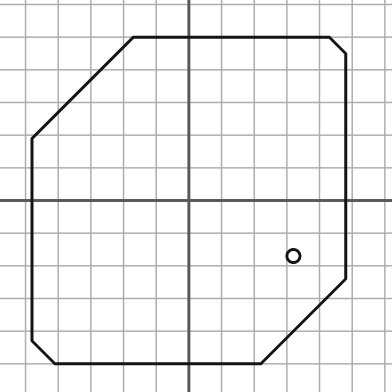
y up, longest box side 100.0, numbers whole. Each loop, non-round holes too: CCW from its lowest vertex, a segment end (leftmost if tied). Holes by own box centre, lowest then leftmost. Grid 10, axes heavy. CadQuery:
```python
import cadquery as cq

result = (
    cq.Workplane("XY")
    .moveTo(-41.0, -50.0)
    .lineTo(22.0, -50.0)
    .lineTo(48.0, -24.0)
    .lineTo(48.0, 45.0)
    .lineTo(43.0, 50.0)
    .lineTo(-17.0, 50.0)
    .lineTo(-48.0, 19.0)
    .lineTo(-48.0, -43.0)
    .close()
    .moveTo(32.0, -17.0)
    .circle(2.0)
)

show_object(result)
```